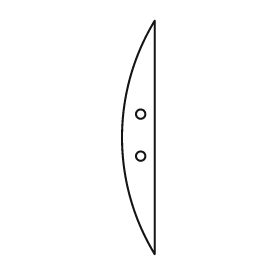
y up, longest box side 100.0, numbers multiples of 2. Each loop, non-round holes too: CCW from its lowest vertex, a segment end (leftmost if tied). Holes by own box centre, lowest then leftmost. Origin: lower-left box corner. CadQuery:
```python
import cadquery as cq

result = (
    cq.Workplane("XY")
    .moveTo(14.0, 0.0)
    .lineTo(14.0, 100.0)
    .threePointArc((0.0, 50.0), (14.0, 0.0))
    .close()
    .moveTo(8.0, 42.0)
    .circle(2.0)
    .moveTo(8.0, 60.0)
    .circle(2.0)
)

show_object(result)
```